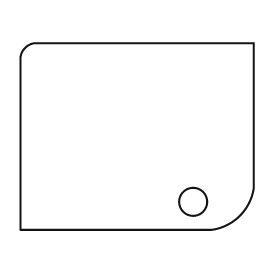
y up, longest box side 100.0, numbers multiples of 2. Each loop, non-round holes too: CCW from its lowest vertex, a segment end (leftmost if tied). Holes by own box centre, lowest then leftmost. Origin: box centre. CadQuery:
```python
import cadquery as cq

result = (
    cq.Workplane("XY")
    .moveTo(-50.0, -40.0)
    .lineTo(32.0, -40.0)
    .threePointArc((44.0, -34.0), (50.0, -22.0))
    .lineTo(50.0, 40.0)
    .lineTo(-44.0, 40.0)
    .threePointArc((-48.0, 38.0), (-50.0, 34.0))
    .close()
    .moveTo(24.0, -28.0)
    .circle(6.0)
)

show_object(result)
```